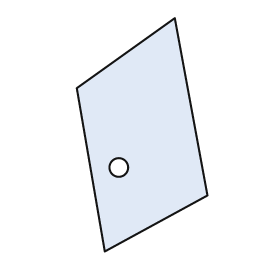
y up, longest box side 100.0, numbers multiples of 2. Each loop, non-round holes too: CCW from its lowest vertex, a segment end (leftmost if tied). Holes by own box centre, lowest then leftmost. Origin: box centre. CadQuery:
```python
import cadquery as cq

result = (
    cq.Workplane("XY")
    .moveTo(-16.0, -50.0)
    .lineTo(28.0, -26.0)
    .lineTo(14.0, 50.0)
    .lineTo(-28.0, 20.0)
    .close()
    .moveTo(-10.0, -14.0)
    .circle(4.0)
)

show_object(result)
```